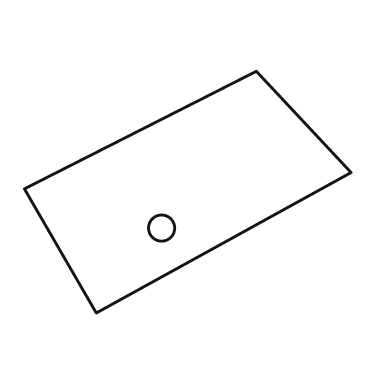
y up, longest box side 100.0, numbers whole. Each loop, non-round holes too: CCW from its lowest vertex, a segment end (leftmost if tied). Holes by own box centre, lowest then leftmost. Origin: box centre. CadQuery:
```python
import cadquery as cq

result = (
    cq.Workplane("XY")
    .moveTo(-28.0, -37.0)
    .lineTo(50.0, 6.0)
    .lineTo(21.0, 37.0)
    .lineTo(-50.0, 1.0)
    .close()
    .moveTo(-8.0, -11.0)
    .circle(4.0)
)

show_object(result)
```